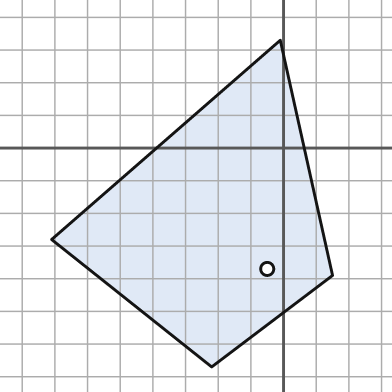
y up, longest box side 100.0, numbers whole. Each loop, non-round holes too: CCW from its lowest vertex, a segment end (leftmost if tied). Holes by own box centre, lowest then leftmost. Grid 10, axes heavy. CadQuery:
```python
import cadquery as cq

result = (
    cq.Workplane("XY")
    .moveTo(-22.0, -67.0)
    .lineTo(15.0, -39.0)
    .lineTo(-1.0, 33.0)
    .lineTo(-71.0, -28.0)
    .close()
    .moveTo(-5.0, -37.0)
    .circle(2.0)
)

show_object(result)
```